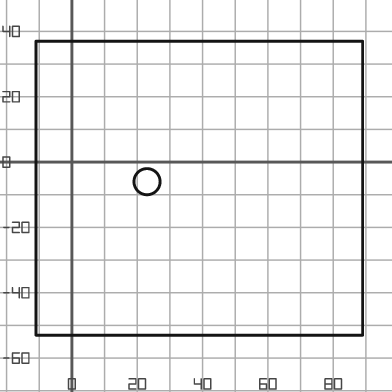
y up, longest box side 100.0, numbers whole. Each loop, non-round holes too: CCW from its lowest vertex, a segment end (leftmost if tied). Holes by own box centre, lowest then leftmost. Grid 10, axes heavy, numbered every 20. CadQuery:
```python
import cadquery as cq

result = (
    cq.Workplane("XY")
    .moveTo(-11.0, -53.0)
    .lineTo(89.0, -53.0)
    .lineTo(89.0, 37.0)
    .lineTo(-11.0, 37.0)
    .close()
    .moveTo(23.0, -6.0)
    .circle(4.0)
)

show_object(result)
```